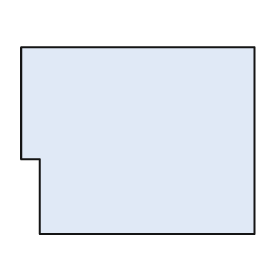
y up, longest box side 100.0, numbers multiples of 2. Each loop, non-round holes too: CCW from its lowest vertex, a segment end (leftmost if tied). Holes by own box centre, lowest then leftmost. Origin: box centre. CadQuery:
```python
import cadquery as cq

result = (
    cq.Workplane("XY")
    .moveTo(-42.0, -40.0)
    .lineTo(50.0, -40.0)
    .lineTo(50.0, 40.0)
    .lineTo(-50.0, 40.0)
    .lineTo(-50.0, -8.0)
    .lineTo(-42.0, -8.0)
    .close()
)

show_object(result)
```